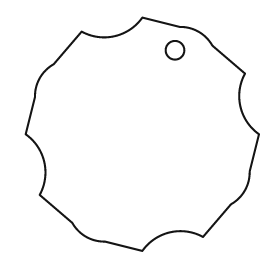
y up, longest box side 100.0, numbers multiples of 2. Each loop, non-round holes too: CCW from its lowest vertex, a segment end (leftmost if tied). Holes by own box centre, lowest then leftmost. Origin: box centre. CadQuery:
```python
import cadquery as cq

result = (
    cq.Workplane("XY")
    .moveTo(0.0, -50.0)
    .threePointArc((12.0, -42.0), (26.0, -44.0))
    .lineTo(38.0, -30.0)
    .threePointArc((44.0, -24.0), (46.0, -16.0))
    .lineTo(50.0, 0.0)
    .threePointArc((42.0, 12.0), (44.0, 26.0))
    .lineTo(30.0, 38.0)
    .threePointArc((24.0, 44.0), (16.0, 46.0))
    .lineTo(0.0, 50.0)
    .threePointArc((-12.0, 42.0), (-26.0, 44.0))
    .lineTo(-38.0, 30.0)
    .threePointArc((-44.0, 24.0), (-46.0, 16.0))
    .lineTo(-50.0, 0.0)
    .threePointArc((-42.0, -12.0), (-44.0, -26.0))
    .lineTo(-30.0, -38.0)
    .threePointArc((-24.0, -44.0), (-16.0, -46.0))
    .close()
    .moveTo(14.0, 36.0)
    .circle(4.0)
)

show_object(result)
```